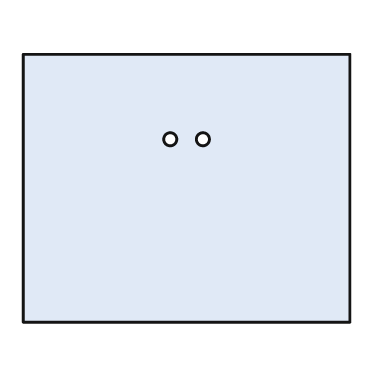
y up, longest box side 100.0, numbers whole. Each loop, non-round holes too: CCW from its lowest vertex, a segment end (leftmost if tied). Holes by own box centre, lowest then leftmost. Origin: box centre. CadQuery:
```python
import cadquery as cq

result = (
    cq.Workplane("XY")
    .moveTo(-50.0, -41.0)
    .lineTo(50.0, -41.0)
    .lineTo(50.0, 41.0)
    .lineTo(-50.0, 41.0)
    .close()
    .moveTo(-5.0, 15.0)
    .circle(2.0)
    .moveTo(5.0, 15.0)
    .circle(2.0)
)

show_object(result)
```